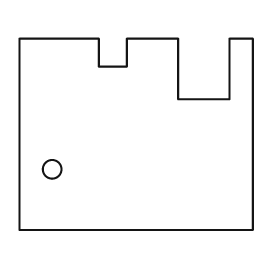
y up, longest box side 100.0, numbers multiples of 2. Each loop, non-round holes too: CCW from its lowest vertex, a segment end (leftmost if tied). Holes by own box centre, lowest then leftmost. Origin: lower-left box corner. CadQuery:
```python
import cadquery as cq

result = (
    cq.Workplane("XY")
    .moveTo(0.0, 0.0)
    .lineTo(100.0, 0.0)
    .lineTo(100.0, 82.0)
    .lineTo(90.0, 82.0)
    .lineTo(90.0, 56.0)
    .lineTo(68.0, 56.0)
    .lineTo(68.0, 82.0)
    .lineTo(46.0, 82.0)
    .lineTo(46.0, 70.0)
    .lineTo(34.0, 70.0)
    .lineTo(34.0, 82.0)
    .lineTo(0.0, 82.0)
    .close()
    .moveTo(14.0, 26.0)
    .circle(4.0)
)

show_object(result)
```